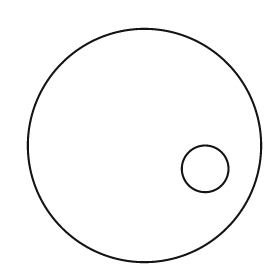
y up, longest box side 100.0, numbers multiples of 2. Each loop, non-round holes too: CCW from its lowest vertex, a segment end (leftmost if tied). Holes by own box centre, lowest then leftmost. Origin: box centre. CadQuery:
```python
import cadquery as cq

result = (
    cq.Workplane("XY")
    .moveTo(0.0, 0.0)
    .circle(50.0)
    .moveTo(26.0, -10.0)
    .circle(10.0)
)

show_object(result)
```